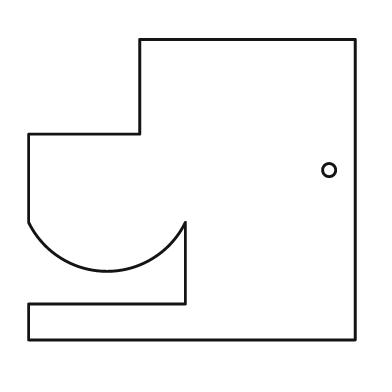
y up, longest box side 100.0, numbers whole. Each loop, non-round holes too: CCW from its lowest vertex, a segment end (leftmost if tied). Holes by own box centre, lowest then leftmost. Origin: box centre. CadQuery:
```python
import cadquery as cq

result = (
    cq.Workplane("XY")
    .moveTo(-50.0, -46.0)
    .lineTo(50.0, -46.0)
    .lineTo(50.0, 46.0)
    .lineTo(-16.0, 46.0)
    .lineTo(-16.0, 17.0)
    .lineTo(-50.0, 17.0)
    .lineTo(-50.0, -10.0)
    .threePointArc((-26.0, -25.0), (-2.0, -10.0))
    .lineTo(-2.0, -35.0)
    .lineTo(-50.0, -35.0)
    .close()
    .moveTo(42.0, 6.0)
    .circle(2.0)
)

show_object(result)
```